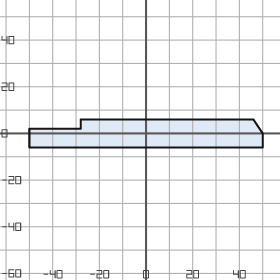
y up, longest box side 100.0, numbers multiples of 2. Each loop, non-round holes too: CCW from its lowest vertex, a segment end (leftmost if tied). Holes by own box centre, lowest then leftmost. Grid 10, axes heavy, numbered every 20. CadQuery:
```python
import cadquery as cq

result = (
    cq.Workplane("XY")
    .moveTo(-50.0, -6.0)
    .lineTo(50.0, -6.0)
    .lineTo(50.0, 0.0)
    .lineTo(46.0, 6.0)
    .lineTo(-28.0, 6.0)
    .lineTo(-28.0, 2.0)
    .lineTo(-50.0, 2.0)
    .close()
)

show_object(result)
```